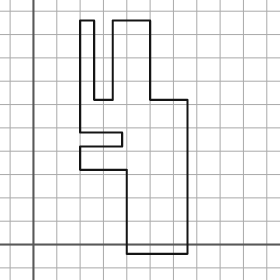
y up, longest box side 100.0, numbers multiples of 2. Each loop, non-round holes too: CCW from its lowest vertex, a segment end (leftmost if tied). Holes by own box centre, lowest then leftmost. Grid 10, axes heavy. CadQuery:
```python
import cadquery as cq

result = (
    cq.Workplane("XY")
    .moveTo(40.0, -4.0)
    .lineTo(66.0, -4.0)
    .lineTo(66.0, 62.0)
    .lineTo(50.0, 62.0)
    .lineTo(50.0, 96.0)
    .lineTo(34.0, 96.0)
    .lineTo(34.0, 62.0)
    .lineTo(26.0, 62.0)
    .lineTo(26.0, 96.0)
    .lineTo(20.0, 96.0)
    .lineTo(20.0, 48.0)
    .lineTo(38.0, 48.0)
    .lineTo(38.0, 42.0)
    .lineTo(20.0, 42.0)
    .lineTo(20.0, 32.0)
    .lineTo(40.0, 32.0)
    .close()
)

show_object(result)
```